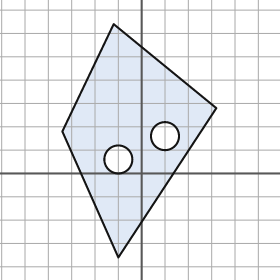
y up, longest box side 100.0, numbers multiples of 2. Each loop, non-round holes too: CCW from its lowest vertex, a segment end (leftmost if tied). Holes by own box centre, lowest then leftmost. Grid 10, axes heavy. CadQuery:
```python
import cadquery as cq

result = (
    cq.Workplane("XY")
    .moveTo(-10.0, -36.0)
    .lineTo(32.0, 28.0)
    .lineTo(-12.0, 64.0)
    .lineTo(-34.0, 18.0)
    .close()
    .moveTo(-10.0, 6.0)
    .circle(6.0)
    .moveTo(10.0, 16.0)
    .circle(6.0)
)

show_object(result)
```